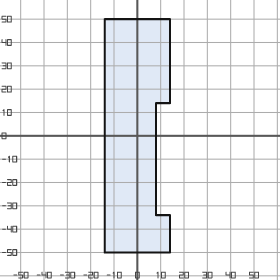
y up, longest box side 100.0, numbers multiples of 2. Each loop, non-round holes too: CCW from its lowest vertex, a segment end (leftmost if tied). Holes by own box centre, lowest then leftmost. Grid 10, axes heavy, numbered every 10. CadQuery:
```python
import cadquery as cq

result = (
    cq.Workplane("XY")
    .moveTo(-14.0, -50.0)
    .lineTo(14.0, -50.0)
    .lineTo(14.0, -34.0)
    .lineTo(8.0, -34.0)
    .lineTo(8.0, 14.0)
    .lineTo(14.0, 14.0)
    .lineTo(14.0, 50.0)
    .lineTo(-14.0, 50.0)
    .close()
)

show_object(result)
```